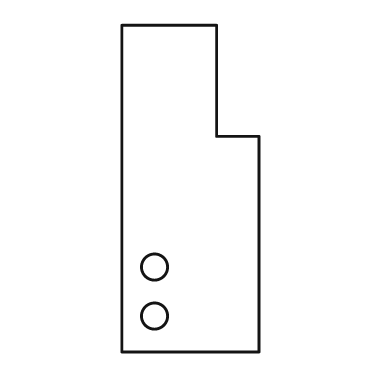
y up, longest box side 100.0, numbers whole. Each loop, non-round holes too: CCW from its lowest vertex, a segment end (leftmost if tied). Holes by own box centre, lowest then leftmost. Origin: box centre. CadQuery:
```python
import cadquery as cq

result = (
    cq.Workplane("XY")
    .moveTo(-21.0, -50.0)
    .lineTo(21.0, -50.0)
    .lineTo(21.0, 16.0)
    .lineTo(8.0, 16.0)
    .lineTo(8.0, 50.0)
    .lineTo(-21.0, 50.0)
    .close()
    .moveTo(-11.0, -39.0)
    .circle(4.0)
    .moveTo(-11.0, -24.0)
    .circle(4.0)
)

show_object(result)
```